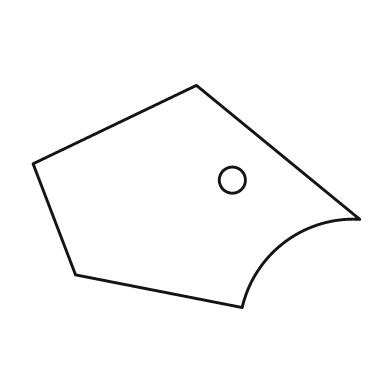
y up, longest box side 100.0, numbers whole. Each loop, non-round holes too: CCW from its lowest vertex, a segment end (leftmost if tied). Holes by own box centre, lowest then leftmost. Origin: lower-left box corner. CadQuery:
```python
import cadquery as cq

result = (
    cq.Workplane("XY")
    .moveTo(64.0, 0.0)
    .threePointArc((77.0, 20.0), (100.0, 27.0))
    .lineTo(50.0, 68.0)
    .lineTo(0.0, 44.0)
    .lineTo(13.0, 10.0)
    .close()
    .moveTo(61.0, 39.0)
    .circle(4.0)
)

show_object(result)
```